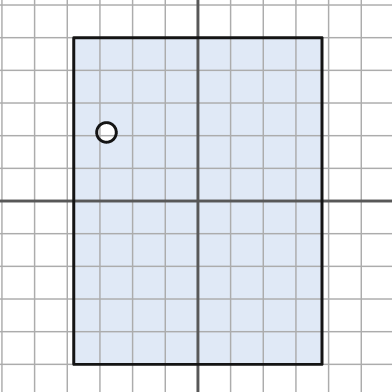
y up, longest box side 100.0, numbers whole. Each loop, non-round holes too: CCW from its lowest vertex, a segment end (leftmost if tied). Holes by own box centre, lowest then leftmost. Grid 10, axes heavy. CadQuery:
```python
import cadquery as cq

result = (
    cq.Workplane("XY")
    .moveTo(-38.0, -50.0)
    .lineTo(38.0, -50.0)
    .lineTo(38.0, 50.0)
    .lineTo(-38.0, 50.0)
    .close()
    .moveTo(-28.0, 21.0)
    .circle(3.0)
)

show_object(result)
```